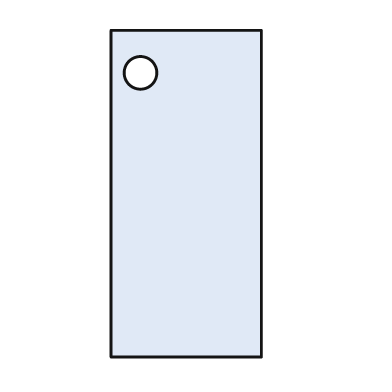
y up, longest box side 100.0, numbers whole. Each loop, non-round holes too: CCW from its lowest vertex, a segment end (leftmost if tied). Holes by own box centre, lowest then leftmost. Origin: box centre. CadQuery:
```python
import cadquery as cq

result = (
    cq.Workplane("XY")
    .moveTo(-23.0, -50.0)
    .lineTo(23.0, -50.0)
    .lineTo(23.0, 50.0)
    .lineTo(-23.0, 50.0)
    .close()
    .moveTo(-14.0, 37.0)
    .circle(5.0)
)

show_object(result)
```